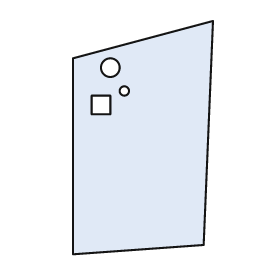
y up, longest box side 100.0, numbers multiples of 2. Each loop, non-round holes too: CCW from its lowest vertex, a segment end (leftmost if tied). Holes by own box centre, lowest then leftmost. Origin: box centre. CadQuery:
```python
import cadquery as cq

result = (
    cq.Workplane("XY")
    .moveTo(-30.0, -50.0)
    .lineTo(26.0, -46.0)
    .lineTo(30.0, 50.0)
    .lineTo(-30.0, 34.0)
    .close()
    .moveTo(-22.0, 10.0)
    .lineTo(-14.0, 10.0)
    .lineTo(-14.0, 18.0)
    .lineTo(-22.0, 18.0)
    .close()
    .moveTo(-8.0, 20.0)
    .circle(2.0)
    .moveTo(-14.0, 30.0)
    .circle(4.0)
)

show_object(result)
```